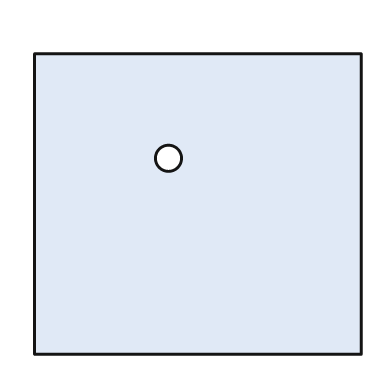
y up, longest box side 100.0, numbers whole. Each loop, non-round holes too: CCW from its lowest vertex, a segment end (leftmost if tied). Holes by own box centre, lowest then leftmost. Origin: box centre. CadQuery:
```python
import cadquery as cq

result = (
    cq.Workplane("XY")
    .moveTo(-50.0, -46.0)
    .lineTo(50.0, -46.0)
    .lineTo(50.0, 46.0)
    .lineTo(-50.0, 46.0)
    .close()
    .moveTo(-9.0, 14.0)
    .circle(4.0)
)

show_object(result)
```